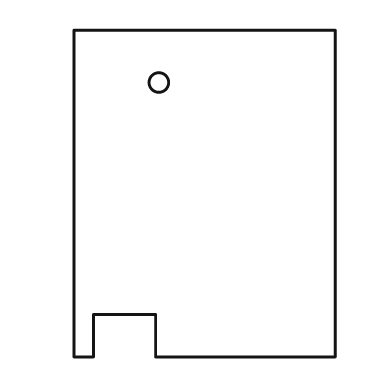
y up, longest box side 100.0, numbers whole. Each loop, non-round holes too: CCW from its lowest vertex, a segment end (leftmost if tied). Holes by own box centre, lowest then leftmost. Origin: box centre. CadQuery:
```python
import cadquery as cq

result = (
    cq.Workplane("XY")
    .moveTo(-40.0, -50.0)
    .lineTo(-34.0, -50.0)
    .lineTo(-34.0, -37.0)
    .lineTo(-15.0, -37.0)
    .lineTo(-15.0, -50.0)
    .lineTo(40.0, -50.0)
    .lineTo(40.0, 50.0)
    .lineTo(-40.0, 50.0)
    .close()
    .moveTo(-14.0, 34.0)
    .circle(3.0)
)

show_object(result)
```